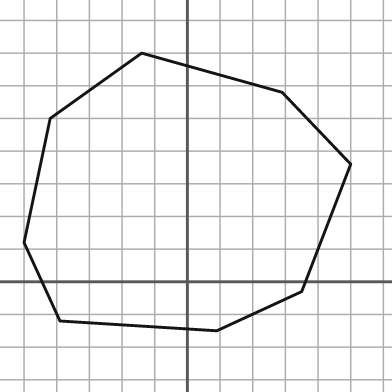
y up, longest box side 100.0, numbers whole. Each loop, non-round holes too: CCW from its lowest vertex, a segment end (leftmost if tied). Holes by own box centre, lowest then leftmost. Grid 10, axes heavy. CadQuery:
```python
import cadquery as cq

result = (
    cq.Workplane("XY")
    .moveTo(9.0, -15.0)
    .lineTo(35.0, -3.0)
    .lineTo(50.0, 36.0)
    .lineTo(29.0, 58.0)
    .lineTo(-14.0, 70.0)
    .lineTo(-42.0, 50.0)
    .lineTo(-50.0, 12.0)
    .lineTo(-39.0, -12.0)
    .close()
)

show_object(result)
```